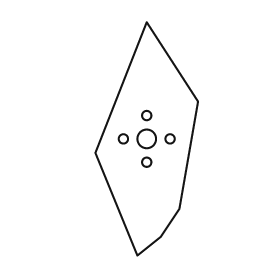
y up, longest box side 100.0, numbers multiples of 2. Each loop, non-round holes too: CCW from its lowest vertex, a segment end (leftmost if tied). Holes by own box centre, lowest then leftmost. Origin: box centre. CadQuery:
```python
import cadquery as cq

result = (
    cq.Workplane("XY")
    .moveTo(-4.0, -50.0)
    .lineTo(6.0, -42.0)
    .lineTo(14.0, -30.0)
    .lineTo(22.0, 16.0)
    .lineTo(0.0, 50.0)
    .lineTo(-22.0, -6.0)
    .close()
    .moveTo(0.0, -10.0)
    .circle(2.0)
    .moveTo(-10.0, 0.0)
    .circle(2.0)
    .moveTo(0.0, 0.0)
    .circle(4.0)
    .moveTo(10.0, 0.0)
    .circle(2.0)
    .moveTo(0.0, 10.0)
    .circle(2.0)
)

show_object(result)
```